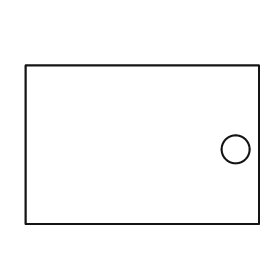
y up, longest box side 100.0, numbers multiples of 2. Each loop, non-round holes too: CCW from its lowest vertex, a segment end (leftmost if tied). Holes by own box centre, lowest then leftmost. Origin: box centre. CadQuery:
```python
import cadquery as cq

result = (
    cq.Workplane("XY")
    .moveTo(-50.0, -34.0)
    .lineTo(50.0, -34.0)
    .lineTo(50.0, 34.0)
    .lineTo(-50.0, 34.0)
    .close()
    .moveTo(40.0, -2.0)
    .circle(6.0)
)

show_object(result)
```